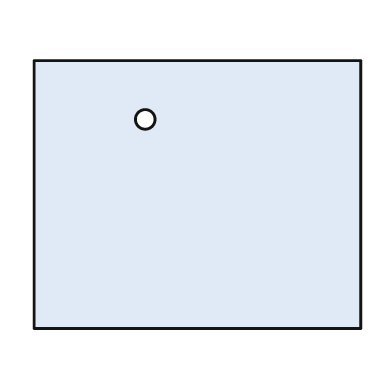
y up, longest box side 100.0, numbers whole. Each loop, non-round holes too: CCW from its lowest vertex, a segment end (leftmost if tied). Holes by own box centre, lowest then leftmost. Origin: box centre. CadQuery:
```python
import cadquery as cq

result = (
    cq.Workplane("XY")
    .moveTo(-50.0, -41.0)
    .lineTo(50.0, -41.0)
    .lineTo(50.0, 41.0)
    .lineTo(-50.0, 41.0)
    .close()
    .moveTo(-16.0, 23.0)
    .circle(3.0)
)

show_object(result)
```